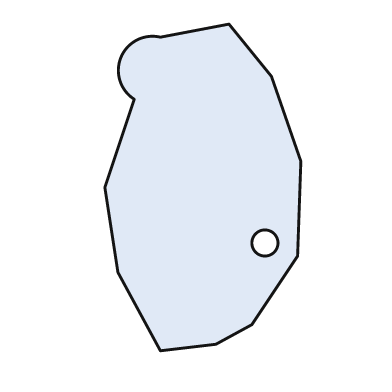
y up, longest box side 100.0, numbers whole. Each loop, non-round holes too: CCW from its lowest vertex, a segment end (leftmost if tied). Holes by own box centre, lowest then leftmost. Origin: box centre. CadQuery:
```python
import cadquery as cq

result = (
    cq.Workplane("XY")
    .moveTo(-13.0, -50.0)
    .lineTo(4.0, -48.0)
    .lineTo(15.0, -42.0)
    .lineTo(29.0, -21.0)
    .lineTo(30.0, 8.0)
    .lineTo(21.0, 34.0)
    .lineTo(8.0, 50.0)
    .lineTo(-13.0, 46.0)
    .threePointArc((-25.0, 40.0), (-21.0, 27.0))
    .lineTo(-30.0, 0.0)
    .lineTo(-26.0, -26.0)
    .close()
    .moveTo(19.0, -17.0)
    .circle(4.0)
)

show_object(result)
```